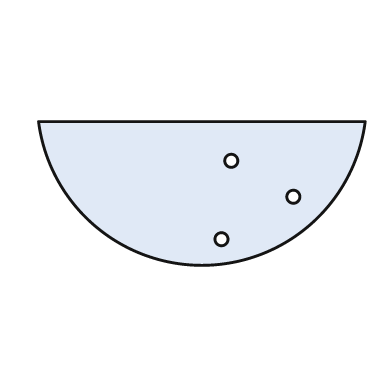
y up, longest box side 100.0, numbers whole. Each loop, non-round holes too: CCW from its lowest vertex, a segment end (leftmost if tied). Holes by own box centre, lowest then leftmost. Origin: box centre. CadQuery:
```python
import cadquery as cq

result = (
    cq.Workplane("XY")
    .moveTo(-50.0, 22.0)
    .threePointArc((0.0, -22.0), (50.0, 22.0))
    .close()
    .moveTo(6.0, -14.0)
    .circle(2.0)
    .moveTo(28.0, -1.0)
    .circle(2.0)
    .moveTo(9.0, 10.0)
    .circle(2.0)
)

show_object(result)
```